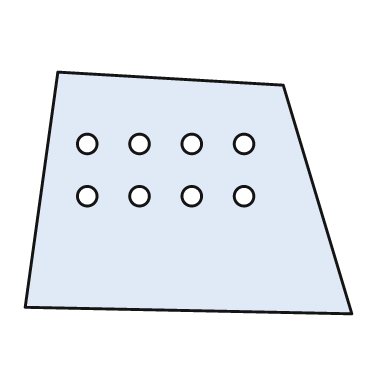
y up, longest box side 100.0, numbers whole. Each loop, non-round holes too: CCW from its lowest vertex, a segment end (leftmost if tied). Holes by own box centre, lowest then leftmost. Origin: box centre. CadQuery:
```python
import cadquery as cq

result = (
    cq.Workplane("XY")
    .moveTo(50.0, -37.0)
    .lineTo(29.0, 33.0)
    .lineTo(-40.0, 37.0)
    .lineTo(-50.0, -35.0)
    .close()
    .moveTo(-31.0, -1.0)
    .circle(3.0)
    .moveTo(-15.0, -1.0)
    .circle(3.0)
    .moveTo(1.0, -1.0)
    .circle(3.0)
    .moveTo(17.0, -1.0)
    .circle(3.0)
    .moveTo(-31.0, 15.0)
    .circle(3.0)
    .moveTo(-15.0, 15.0)
    .circle(3.0)
    .moveTo(1.0, 15.0)
    .circle(3.0)
    .moveTo(17.0, 15.0)
    .circle(3.0)
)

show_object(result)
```